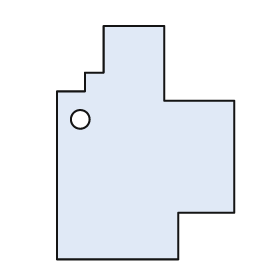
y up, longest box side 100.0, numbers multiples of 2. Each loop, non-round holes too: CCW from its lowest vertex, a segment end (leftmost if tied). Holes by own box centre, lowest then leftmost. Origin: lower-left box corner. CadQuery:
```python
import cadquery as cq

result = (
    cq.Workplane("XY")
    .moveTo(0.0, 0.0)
    .lineTo(52.0, 0.0)
    .lineTo(52.0, 20.0)
    .lineTo(76.0, 20.0)
    .lineTo(76.0, 68.0)
    .lineTo(46.0, 68.0)
    .lineTo(46.0, 100.0)
    .lineTo(20.0, 100.0)
    .lineTo(20.0, 80.0)
    .lineTo(12.0, 80.0)
    .lineTo(12.0, 72.0)
    .lineTo(0.0, 72.0)
    .close()
    .moveTo(10.0, 60.0)
    .circle(4.0)
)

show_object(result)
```